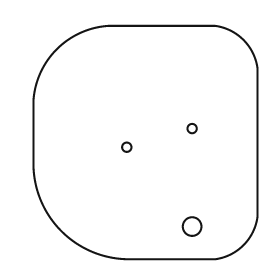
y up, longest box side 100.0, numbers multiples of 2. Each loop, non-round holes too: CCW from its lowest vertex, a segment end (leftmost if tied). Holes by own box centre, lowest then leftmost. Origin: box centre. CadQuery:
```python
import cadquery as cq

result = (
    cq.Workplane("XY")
    .moveTo(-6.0, -50.0)
    .lineTo(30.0, -50.0)
    .threePointArc((42.0, -44.0), (48.0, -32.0))
    .lineTo(48.0, 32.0)
    .threePointArc((42.0, 44.0), (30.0, 50.0))
    .lineTo(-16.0, 50.0)
    .threePointArc((-38.0, 40.0), (-48.0, 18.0))
    .lineTo(-48.0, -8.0)
    .threePointArc((-36.0, -38.0), (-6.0, -50.0))
    .close()
    .moveTo(20.0, -36.0)
    .circle(4.0)
    .moveTo(-8.0, -2.0)
    .circle(2.0)
    .moveTo(20.0, 6.0)
    .circle(2.0)
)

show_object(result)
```